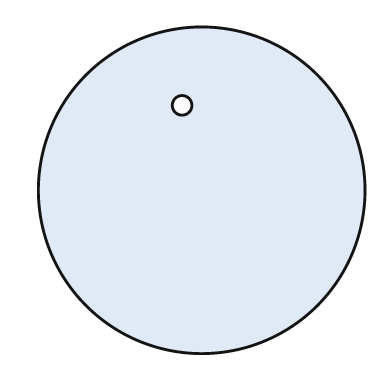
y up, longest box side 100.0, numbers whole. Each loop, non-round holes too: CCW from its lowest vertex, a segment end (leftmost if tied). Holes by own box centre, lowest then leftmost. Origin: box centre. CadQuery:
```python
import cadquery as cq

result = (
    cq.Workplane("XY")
    .moveTo(0.0, 0.0)
    .circle(50.0)
    .moveTo(-6.0, 26.0)
    .circle(3.0)
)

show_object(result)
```